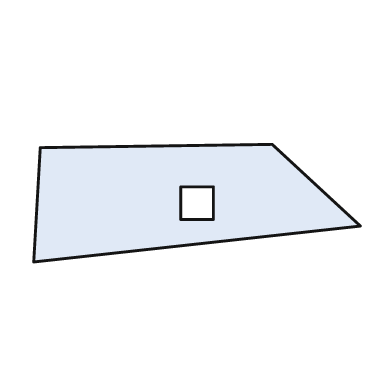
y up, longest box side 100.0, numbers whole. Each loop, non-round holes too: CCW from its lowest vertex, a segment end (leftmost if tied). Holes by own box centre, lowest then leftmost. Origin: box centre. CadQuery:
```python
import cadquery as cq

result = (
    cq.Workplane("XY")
    .moveTo(-50.0, -18.0)
    .lineTo(50.0, -7.0)
    .lineTo(23.0, 18.0)
    .lineTo(-48.0, 17.0)
    .close()
    .moveTo(-5.0, -5.0)
    .lineTo(5.0, -5.0)
    .lineTo(5.0, 5.0)
    .lineTo(-5.0, 5.0)
    .close()
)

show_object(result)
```